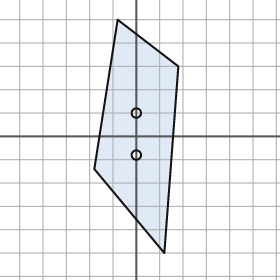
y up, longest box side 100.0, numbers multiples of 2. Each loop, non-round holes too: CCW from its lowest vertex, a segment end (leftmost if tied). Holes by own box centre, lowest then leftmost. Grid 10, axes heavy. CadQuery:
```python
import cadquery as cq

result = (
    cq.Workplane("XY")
    .moveTo(12.0, -50.0)
    .lineTo(18.0, 30.0)
    .lineTo(-8.0, 50.0)
    .lineTo(-18.0, -14.0)
    .close()
    .moveTo(0.0, -8.0)
    .circle(2.0)
    .moveTo(0.0, 10.0)
    .circle(2.0)
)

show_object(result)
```